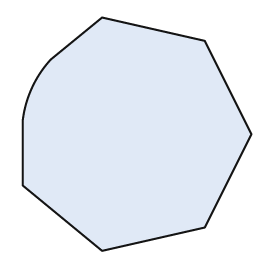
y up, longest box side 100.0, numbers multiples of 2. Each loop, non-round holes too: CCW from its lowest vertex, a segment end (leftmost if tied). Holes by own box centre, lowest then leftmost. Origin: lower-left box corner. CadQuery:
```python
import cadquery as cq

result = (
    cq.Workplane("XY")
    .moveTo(34.0, 0.0)
    .lineTo(78.0, 10.0)
    .lineTo(98.0, 50.0)
    .lineTo(78.0, 90.0)
    .lineTo(34.0, 100.0)
    .lineTo(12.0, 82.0)
    .threePointArc((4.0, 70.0), (0.0, 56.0))
    .lineTo(0.0, 28.0)
    .close()
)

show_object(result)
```